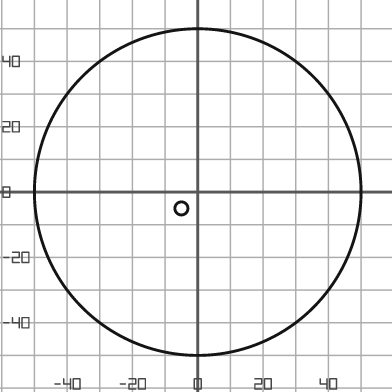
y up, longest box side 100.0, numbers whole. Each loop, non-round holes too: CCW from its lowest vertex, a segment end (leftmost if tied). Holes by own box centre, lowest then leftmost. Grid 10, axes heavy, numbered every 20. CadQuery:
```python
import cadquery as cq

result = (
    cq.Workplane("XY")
    .moveTo(0.0, 0.0)
    .circle(50.0)
    .moveTo(-5.0, -5.0)
    .circle(2.0)
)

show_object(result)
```